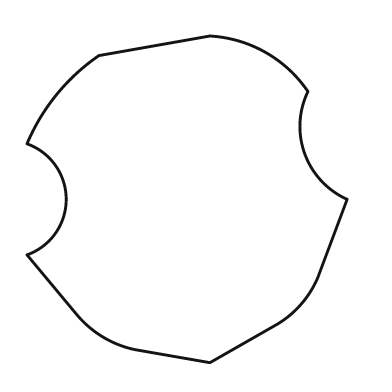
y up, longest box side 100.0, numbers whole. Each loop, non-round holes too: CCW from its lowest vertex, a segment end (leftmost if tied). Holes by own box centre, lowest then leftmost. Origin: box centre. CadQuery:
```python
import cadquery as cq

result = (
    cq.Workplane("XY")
    .moveTo(7.0, -50.0)
    .lineTo(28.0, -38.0)
    .threePointArc((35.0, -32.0), (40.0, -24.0))
    .lineTo(49.0, 0.0)
    .threePointArc((36.0, 14.0), (37.0, 33.0))
    .threePointArc((24.0, 45.0), (7.0, 50.0))
    .lineTo(-27.0, 44.0)
    .threePointArc((-40.0, 32.0), (-49.0, 17.0))
    .threePointArc((-37.0, 0.0), (-49.0, -17.0))
    .lineTo(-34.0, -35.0)
    .threePointArc((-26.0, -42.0), (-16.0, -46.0))
    .close()
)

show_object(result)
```